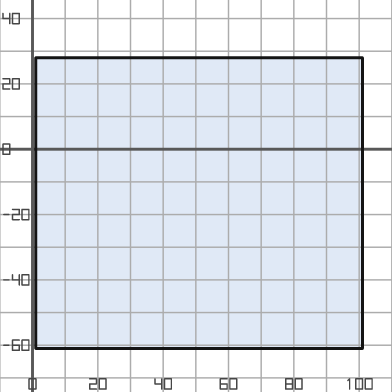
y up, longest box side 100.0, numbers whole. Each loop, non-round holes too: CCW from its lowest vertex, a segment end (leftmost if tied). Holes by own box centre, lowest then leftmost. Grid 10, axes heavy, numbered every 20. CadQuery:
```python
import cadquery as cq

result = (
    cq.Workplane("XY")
    .moveTo(1.0, -61.0)
    .lineTo(101.0, -61.0)
    .lineTo(101.0, 28.0)
    .lineTo(1.0, 28.0)
    .close()
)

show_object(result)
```